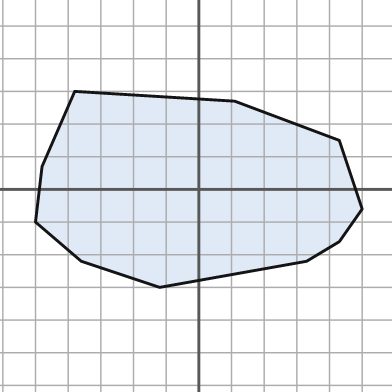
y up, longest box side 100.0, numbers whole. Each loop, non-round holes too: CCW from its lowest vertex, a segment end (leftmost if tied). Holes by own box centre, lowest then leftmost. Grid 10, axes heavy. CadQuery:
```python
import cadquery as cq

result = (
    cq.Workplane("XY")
    .moveTo(-12.0, -30.0)
    .lineTo(33.0, -22.0)
    .lineTo(43.0, -16.0)
    .lineTo(50.0, -6.0)
    .lineTo(43.0, 15.0)
    .lineTo(11.0, 27.0)
    .lineTo(-38.0, 30.0)
    .lineTo(-48.0, 7.0)
    .lineTo(-50.0, -10.0)
    .lineTo(-36.0, -22.0)
    .close()
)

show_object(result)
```